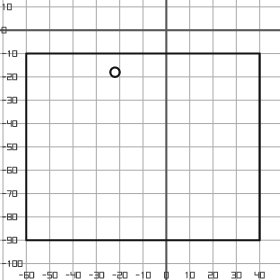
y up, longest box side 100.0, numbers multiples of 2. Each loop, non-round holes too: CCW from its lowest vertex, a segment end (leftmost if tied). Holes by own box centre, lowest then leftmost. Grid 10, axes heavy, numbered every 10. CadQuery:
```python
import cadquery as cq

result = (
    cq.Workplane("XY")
    .moveTo(-60.0, -90.0)
    .lineTo(40.0, -90.0)
    .lineTo(40.0, -10.0)
    .lineTo(-60.0, -10.0)
    .close()
    .moveTo(-22.0, -18.0)
    .circle(2.0)
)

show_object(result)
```